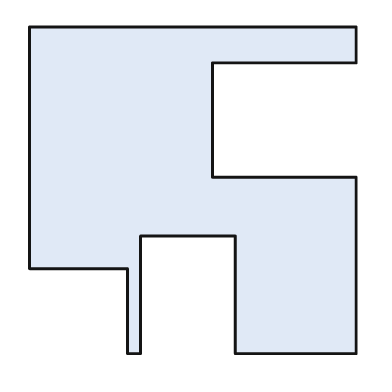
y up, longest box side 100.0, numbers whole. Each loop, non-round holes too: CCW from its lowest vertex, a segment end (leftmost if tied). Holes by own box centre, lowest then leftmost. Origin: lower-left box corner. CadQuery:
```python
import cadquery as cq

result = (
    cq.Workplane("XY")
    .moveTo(30.0, 0.0)
    .lineTo(34.0, 0.0)
    .lineTo(34.0, 36.0)
    .lineTo(63.0, 36.0)
    .lineTo(63.0, 0.0)
    .lineTo(100.0, 0.0)
    .lineTo(100.0, 54.0)
    .lineTo(56.0, 54.0)
    .lineTo(56.0, 89.0)
    .lineTo(100.0, 89.0)
    .lineTo(100.0, 100.0)
    .lineTo(0.0, 100.0)
    .lineTo(0.0, 26.0)
    .lineTo(30.0, 26.0)
    .close()
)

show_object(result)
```